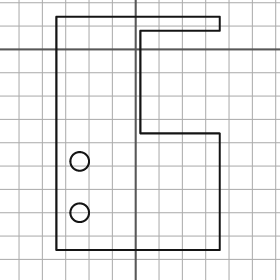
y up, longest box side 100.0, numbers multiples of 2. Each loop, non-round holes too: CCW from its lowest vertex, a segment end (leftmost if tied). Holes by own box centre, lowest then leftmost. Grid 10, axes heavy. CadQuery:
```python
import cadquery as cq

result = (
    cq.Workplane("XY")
    .moveTo(-34.0, -86.0)
    .lineTo(36.0, -86.0)
    .lineTo(36.0, -36.0)
    .lineTo(2.0, -36.0)
    .lineTo(2.0, 8.0)
    .lineTo(36.0, 8.0)
    .lineTo(36.0, 14.0)
    .lineTo(-34.0, 14.0)
    .close()
    .moveTo(-24.0, -70.0)
    .circle(4.0)
    .moveTo(-24.0, -48.0)
    .circle(4.0)
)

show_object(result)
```